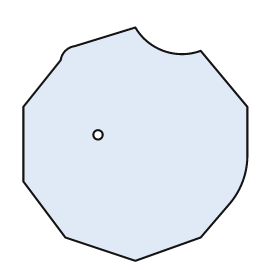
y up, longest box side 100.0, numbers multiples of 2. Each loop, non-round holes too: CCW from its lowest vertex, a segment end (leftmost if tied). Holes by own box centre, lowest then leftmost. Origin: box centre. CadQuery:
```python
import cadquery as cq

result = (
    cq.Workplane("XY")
    .moveTo(0.0, -50.0)
    .lineTo(28.0, -40.0)
    .lineTo(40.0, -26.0)
    .threePointArc((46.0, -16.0), (48.0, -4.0))
    .lineTo(48.0, 16.0)
    .lineTo(28.0, 40.0)
    .threePointArc((12.0, 40.0), (0.0, 50.0))
    .lineTo(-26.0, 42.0)
    .threePointArc((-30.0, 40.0), (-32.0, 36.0))
    .lineTo(-48.0, 16.0)
    .lineTo(-48.0, -16.0)
    .lineTo(-30.0, -40.0)
    .close()
    .moveTo(-16.0, 4.0)
    .circle(2.0)
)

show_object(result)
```